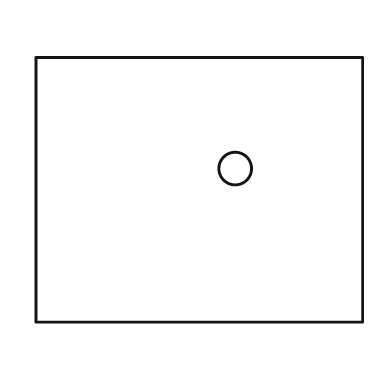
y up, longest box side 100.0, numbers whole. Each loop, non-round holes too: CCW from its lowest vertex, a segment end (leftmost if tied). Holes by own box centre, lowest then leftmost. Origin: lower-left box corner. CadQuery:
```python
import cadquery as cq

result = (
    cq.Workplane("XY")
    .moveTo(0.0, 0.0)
    .lineTo(100.0, 0.0)
    .lineTo(100.0, 81.0)
    .lineTo(0.0, 81.0)
    .close()
    .moveTo(61.0, 47.0)
    .circle(5.0)
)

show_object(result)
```